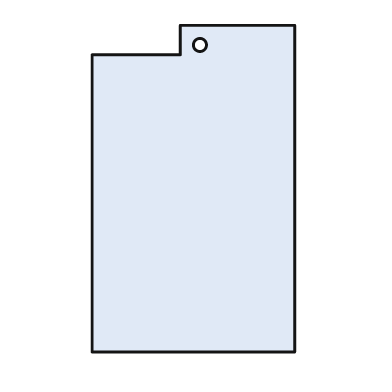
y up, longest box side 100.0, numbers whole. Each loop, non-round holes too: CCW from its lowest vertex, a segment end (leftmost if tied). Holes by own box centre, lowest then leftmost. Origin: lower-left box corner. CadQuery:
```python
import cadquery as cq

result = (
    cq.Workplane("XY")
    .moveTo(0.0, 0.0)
    .lineTo(62.0, 0.0)
    .lineTo(62.0, 100.0)
    .lineTo(27.0, 100.0)
    .lineTo(27.0, 91.0)
    .lineTo(0.0, 91.0)
    .close()
    .moveTo(33.0, 94.0)
    .circle(2.0)
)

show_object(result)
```